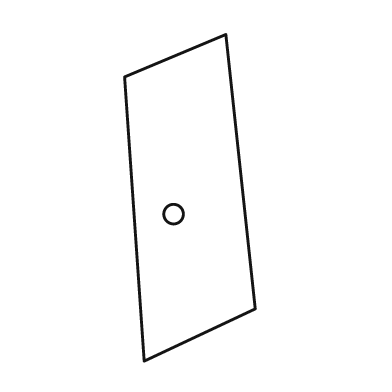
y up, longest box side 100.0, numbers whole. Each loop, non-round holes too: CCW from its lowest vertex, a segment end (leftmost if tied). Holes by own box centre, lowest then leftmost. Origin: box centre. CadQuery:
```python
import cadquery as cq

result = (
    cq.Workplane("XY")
    .moveTo(-14.0, -50.0)
    .lineTo(20.0, -34.0)
    .lineTo(11.0, 50.0)
    .lineTo(-20.0, 37.0)
    .close()
    .moveTo(-5.0, -5.0)
    .circle(3.0)
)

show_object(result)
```